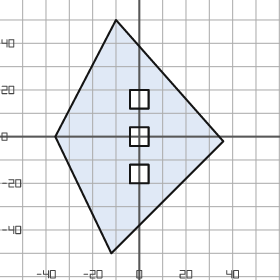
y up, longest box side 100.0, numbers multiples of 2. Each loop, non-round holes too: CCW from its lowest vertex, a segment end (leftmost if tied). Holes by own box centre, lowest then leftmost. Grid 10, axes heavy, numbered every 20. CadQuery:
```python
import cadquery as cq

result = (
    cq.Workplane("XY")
    .moveTo(-12.0, -50.0)
    .lineTo(36.0, -2.0)
    .lineTo(-10.0, 50.0)
    .lineTo(-36.0, 0.0)
    .close()
    .moveTo(-4.0, -20.0)
    .lineTo(4.0, -20.0)
    .lineTo(4.0, -12.0)
    .lineTo(-4.0, -12.0)
    .close()
    .moveTo(-4.0, -4.0)
    .lineTo(4.0, -4.0)
    .lineTo(4.0, 4.0)
    .lineTo(-4.0, 4.0)
    .close()
    .moveTo(-4.0, 12.0)
    .lineTo(4.0, 12.0)
    .lineTo(4.0, 20.0)
    .lineTo(-4.0, 20.0)
    .close()
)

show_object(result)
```